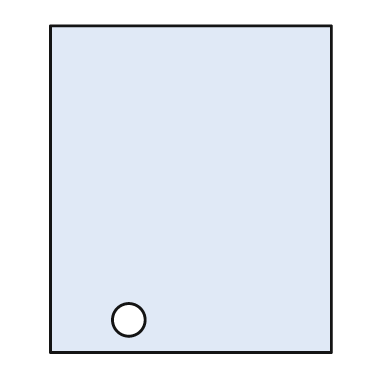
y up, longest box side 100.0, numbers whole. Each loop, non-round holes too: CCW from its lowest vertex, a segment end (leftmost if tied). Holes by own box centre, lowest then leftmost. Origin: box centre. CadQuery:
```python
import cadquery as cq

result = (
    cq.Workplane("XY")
    .moveTo(-43.0, -50.0)
    .lineTo(43.0, -50.0)
    .lineTo(43.0, 50.0)
    .lineTo(-43.0, 50.0)
    .close()
    .moveTo(-19.0, -40.0)
    .circle(5.0)
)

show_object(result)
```